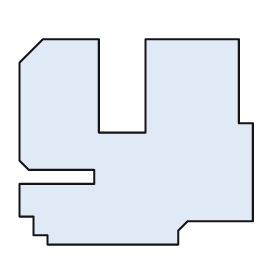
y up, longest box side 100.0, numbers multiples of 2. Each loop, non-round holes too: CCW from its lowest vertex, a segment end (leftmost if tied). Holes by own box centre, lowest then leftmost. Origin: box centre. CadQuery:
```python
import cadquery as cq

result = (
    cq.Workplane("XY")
    .moveTo(-38.0, -44.0)
    .lineTo(18.0, -44.0)
    .lineTo(18.0, -38.0)
    .lineTo(22.0, -34.0)
    .lineTo(50.0, -34.0)
    .lineTo(50.0, 8.0)
    .lineTo(44.0, 8.0)
    .lineTo(44.0, 44.0)
    .lineTo(4.0, 44.0)
    .lineTo(4.0, 4.0)
    .lineTo(-16.0, 4.0)
    .lineTo(-16.0, 44.0)
    .lineTo(-40.0, 44.0)
    .lineTo(-50.0, 34.0)
    .lineTo(-50.0, -8.0)
    .lineTo(-46.0, -12.0)
    .lineTo(-18.0, -12.0)
    .lineTo(-18.0, -18.0)
    .lineTo(-50.0, -18.0)
    .lineTo(-50.0, -32.0)
    .lineTo(-44.0, -32.0)
    .lineTo(-44.0, -40.0)
    .lineTo(-38.0, -40.0)
    .close()
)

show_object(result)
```